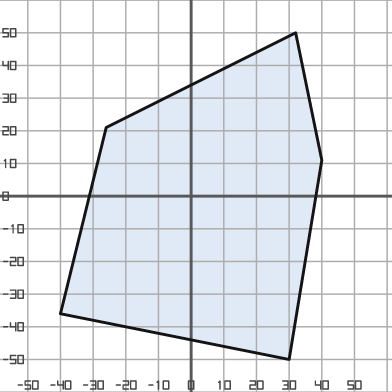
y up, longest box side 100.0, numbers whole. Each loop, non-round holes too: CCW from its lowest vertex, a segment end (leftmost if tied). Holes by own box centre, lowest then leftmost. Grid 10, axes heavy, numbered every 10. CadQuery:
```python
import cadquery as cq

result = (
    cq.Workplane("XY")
    .moveTo(30.0, -50.0)
    .lineTo(40.0, 11.0)
    .lineTo(32.0, 50.0)
    .lineTo(-26.0, 21.0)
    .lineTo(-40.0, -36.0)
    .close()
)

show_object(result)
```